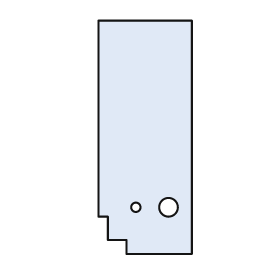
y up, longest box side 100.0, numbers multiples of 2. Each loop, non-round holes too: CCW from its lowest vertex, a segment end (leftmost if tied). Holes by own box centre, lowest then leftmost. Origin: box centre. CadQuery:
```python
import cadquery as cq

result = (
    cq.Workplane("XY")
    .moveTo(-8.0, -50.0)
    .lineTo(20.0, -50.0)
    .lineTo(20.0, 50.0)
    .lineTo(-20.0, 50.0)
    .lineTo(-20.0, -34.0)
    .lineTo(-16.0, -34.0)
    .lineTo(-16.0, -44.0)
    .lineTo(-8.0, -44.0)
    .close()
    .moveTo(-4.0, -30.0)
    .circle(2.0)
    .moveTo(10.0, -30.0)
    .circle(4.0)
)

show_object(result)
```